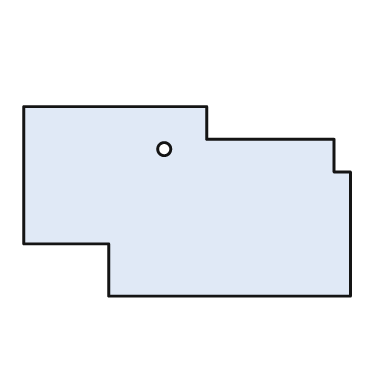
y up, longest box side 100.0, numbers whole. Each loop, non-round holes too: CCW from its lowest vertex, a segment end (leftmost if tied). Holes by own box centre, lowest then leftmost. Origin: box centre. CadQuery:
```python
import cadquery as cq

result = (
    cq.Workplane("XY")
    .moveTo(-24.0, -29.0)
    .lineTo(50.0, -29.0)
    .lineTo(50.0, 9.0)
    .lineTo(45.0, 9.0)
    .lineTo(45.0, 19.0)
    .lineTo(6.0, 19.0)
    .lineTo(6.0, 29.0)
    .lineTo(-50.0, 29.0)
    .lineTo(-50.0, -13.0)
    .lineTo(-24.0, -13.0)
    .close()
    .moveTo(-7.0, 16.0)
    .circle(2.0)
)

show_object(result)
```